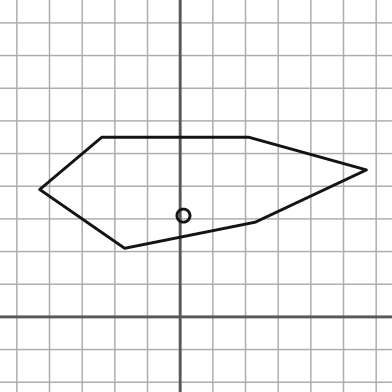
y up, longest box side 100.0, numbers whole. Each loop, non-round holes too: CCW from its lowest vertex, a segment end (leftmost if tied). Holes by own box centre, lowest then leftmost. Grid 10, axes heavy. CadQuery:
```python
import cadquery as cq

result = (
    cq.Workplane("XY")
    .moveTo(-17.0, 21.0)
    .lineTo(23.0, 29.0)
    .lineTo(57.0, 45.0)
    .lineTo(21.0, 55.0)
    .lineTo(-24.0, 55.0)
    .lineTo(-43.0, 39.0)
    .close()
    .moveTo(1.0, 31.0)
    .circle(2.0)
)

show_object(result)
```